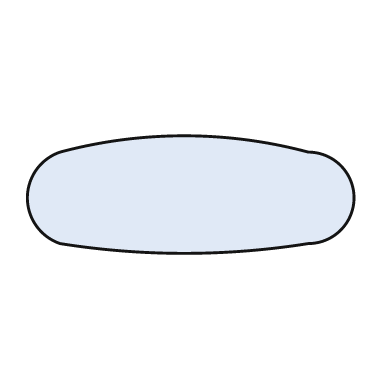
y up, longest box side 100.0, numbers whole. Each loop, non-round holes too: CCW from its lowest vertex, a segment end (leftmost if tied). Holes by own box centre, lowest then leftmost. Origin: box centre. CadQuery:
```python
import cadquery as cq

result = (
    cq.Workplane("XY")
    .moveTo(-40.0, -15.0)
    .threePointArc((-2.0, -18.0), (36.0, -15.0))
    .threePointArc((50.0, -1.0), (36.0, 13.0))
    .threePointArc((-2.0, 18.0), (-40.0, 13.0))
    .threePointArc((-50.0, -1.0), (-40.0, -15.0))
    .close()
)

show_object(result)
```